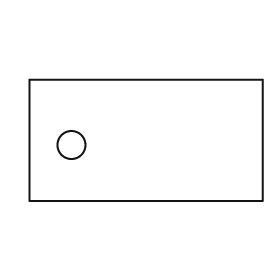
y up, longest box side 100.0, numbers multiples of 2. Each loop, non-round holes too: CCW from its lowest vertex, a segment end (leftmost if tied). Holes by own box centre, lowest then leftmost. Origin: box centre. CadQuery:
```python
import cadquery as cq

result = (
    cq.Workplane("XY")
    .moveTo(-50.0, -26.0)
    .lineTo(50.0, -26.0)
    .lineTo(50.0, 26.0)
    .lineTo(-50.0, 26.0)
    .close()
    .moveTo(-32.0, -2.0)
    .circle(6.0)
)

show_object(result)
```